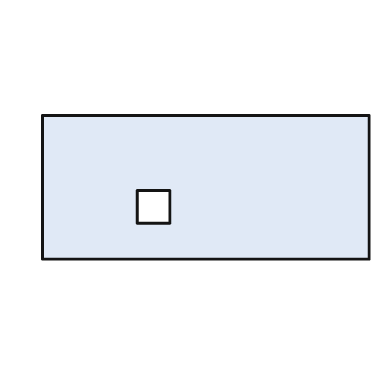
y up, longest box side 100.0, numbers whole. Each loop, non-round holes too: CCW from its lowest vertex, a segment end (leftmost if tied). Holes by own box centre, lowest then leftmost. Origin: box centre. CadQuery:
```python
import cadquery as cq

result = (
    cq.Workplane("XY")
    .moveTo(-50.0, -22.0)
    .lineTo(50.0, -22.0)
    .lineTo(50.0, 22.0)
    .lineTo(-50.0, 22.0)
    .close()
    .moveTo(-21.0, -11.0)
    .lineTo(-11.0, -11.0)
    .lineTo(-11.0, -1.0)
    .lineTo(-21.0, -1.0)
    .close()
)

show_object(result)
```